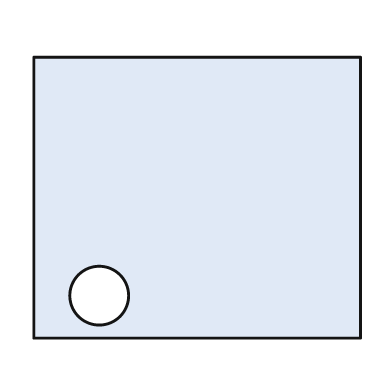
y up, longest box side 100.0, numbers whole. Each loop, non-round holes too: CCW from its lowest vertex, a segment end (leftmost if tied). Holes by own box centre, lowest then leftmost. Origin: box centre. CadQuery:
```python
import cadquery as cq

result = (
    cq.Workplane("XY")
    .moveTo(-50.0, -43.0)
    .lineTo(50.0, -43.0)
    .lineTo(50.0, 43.0)
    .lineTo(-50.0, 43.0)
    .close()
    .moveTo(-30.0, -30.0)
    .circle(9.0)
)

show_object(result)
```